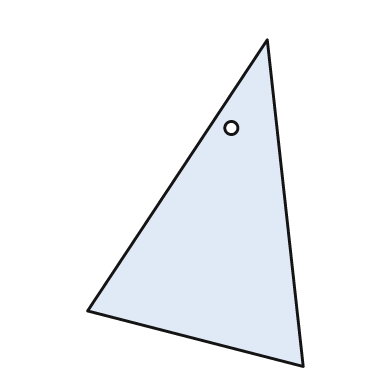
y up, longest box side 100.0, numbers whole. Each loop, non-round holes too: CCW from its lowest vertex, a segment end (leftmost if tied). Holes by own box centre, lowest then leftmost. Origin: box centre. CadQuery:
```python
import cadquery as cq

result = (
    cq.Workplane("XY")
    .moveTo(33.0, -50.0)
    .lineTo(22.0, 50.0)
    .lineTo(-33.0, -33.0)
    .close()
    .moveTo(11.0, 23.0)
    .circle(2.0)
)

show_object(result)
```